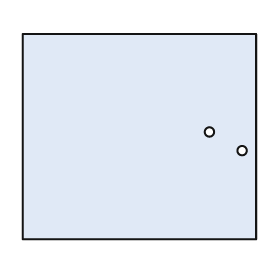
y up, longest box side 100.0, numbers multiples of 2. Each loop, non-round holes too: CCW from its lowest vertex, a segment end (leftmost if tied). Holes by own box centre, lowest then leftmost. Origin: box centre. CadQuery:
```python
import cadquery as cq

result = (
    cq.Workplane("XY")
    .moveTo(-50.0, -44.0)
    .lineTo(50.0, -44.0)
    .lineTo(50.0, 44.0)
    .lineTo(-50.0, 44.0)
    .close()
    .moveTo(44.0, -6.0)
    .circle(2.0)
    .moveTo(30.0, 2.0)
    .circle(2.0)
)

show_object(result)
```